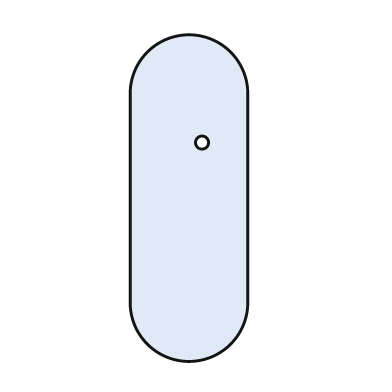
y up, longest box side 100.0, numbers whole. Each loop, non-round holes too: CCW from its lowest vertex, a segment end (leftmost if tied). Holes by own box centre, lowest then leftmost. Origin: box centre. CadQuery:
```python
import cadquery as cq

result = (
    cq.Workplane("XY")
    .moveTo(-18.0, -32.0)
    .threePointArc((0.0, -50.0), (18.0, -32.0))
    .lineTo(18.0, 32.0)
    .threePointArc((0.0, 50.0), (-18.0, 32.0))
    .close()
    .moveTo(4.0, 17.0)
    .circle(2.0)
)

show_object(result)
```